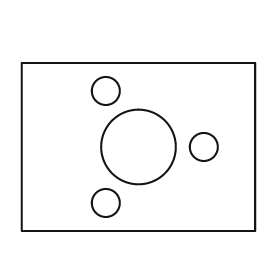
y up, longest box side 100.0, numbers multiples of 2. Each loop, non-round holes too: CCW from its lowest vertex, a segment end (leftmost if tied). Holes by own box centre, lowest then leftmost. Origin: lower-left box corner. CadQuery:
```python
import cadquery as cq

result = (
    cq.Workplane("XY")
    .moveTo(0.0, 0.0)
    .lineTo(100.0, 0.0)
    .lineTo(100.0, 72.0)
    .lineTo(0.0, 72.0)
    .close()
    .moveTo(36.0, 12.0)
    .circle(6.0)
    .moveTo(50.0, 36.0)
    .circle(16.0)
    .moveTo(78.0, 36.0)
    .circle(6.0)
    .moveTo(36.0, 60.0)
    .circle(6.0)
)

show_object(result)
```